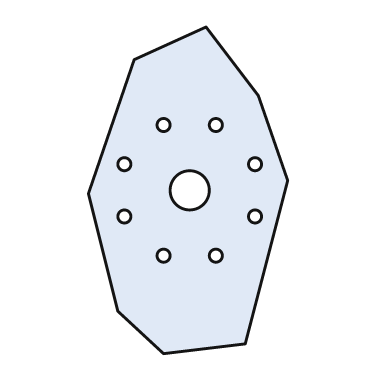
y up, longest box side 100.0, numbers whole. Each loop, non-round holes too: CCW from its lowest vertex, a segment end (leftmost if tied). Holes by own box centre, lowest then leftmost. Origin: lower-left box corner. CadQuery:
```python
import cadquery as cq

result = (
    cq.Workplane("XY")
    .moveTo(23.0, 0.0)
    .lineTo(48.0, 3.0)
    .lineTo(61.0, 53.0)
    .lineTo(52.0, 79.0)
    .lineTo(36.0, 100.0)
    .lineTo(14.0, 90.0)
    .lineTo(0.0, 49.0)
    .lineTo(9.0, 13.0)
    .close()
    .moveTo(23.0, 30.0)
    .circle(2.0)
    .moveTo(39.0, 30.0)
    .circle(2.0)
    .moveTo(11.0, 42.0)
    .circle(2.0)
    .moveTo(51.0, 42.0)
    .circle(2.0)
    .moveTo(31.0, 50.0)
    .circle(6.0)
    .moveTo(11.0, 58.0)
    .circle(2.0)
    .moveTo(51.0, 58.0)
    .circle(2.0)
    .moveTo(23.0, 70.0)
    .circle(2.0)
    .moveTo(39.0, 70.0)
    .circle(2.0)
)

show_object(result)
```